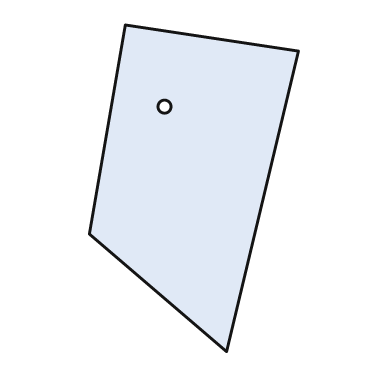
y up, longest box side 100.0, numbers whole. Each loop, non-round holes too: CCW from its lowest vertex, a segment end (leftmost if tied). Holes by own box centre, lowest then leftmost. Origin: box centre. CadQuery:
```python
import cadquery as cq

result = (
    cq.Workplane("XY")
    .moveTo(10.0, -50.0)
    .lineTo(32.0, 42.0)
    .lineTo(-21.0, 50.0)
    .lineTo(-32.0, -14.0)
    .close()
    .moveTo(-9.0, 25.0)
    .circle(2.0)
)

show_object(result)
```